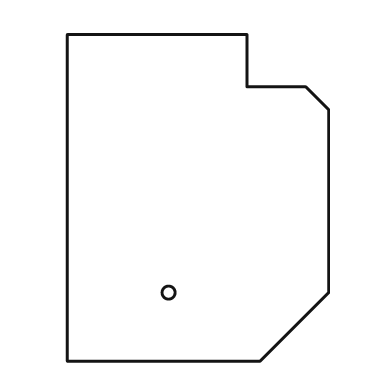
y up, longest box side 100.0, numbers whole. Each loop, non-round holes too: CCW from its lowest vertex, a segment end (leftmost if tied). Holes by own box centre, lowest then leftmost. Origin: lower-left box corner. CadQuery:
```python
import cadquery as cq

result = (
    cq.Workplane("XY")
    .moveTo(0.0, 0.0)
    .lineTo(59.0, 0.0)
    .lineTo(80.0, 21.0)
    .lineTo(80.0, 77.0)
    .lineTo(73.0, 84.0)
    .lineTo(55.0, 84.0)
    .lineTo(55.0, 100.0)
    .lineTo(0.0, 100.0)
    .close()
    .moveTo(31.0, 21.0)
    .circle(2.0)
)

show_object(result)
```